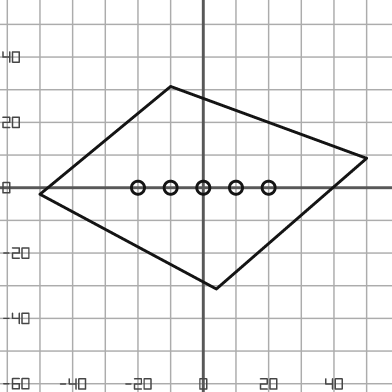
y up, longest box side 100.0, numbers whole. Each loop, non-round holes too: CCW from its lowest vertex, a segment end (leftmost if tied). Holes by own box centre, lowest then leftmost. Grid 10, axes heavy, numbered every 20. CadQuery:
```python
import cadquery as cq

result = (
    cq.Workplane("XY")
    .moveTo(4.0, -31.0)
    .lineTo(50.0, 9.0)
    .lineTo(-10.0, 31.0)
    .lineTo(-50.0, -2.0)
    .close()
    .moveTo(-20.0, 0.0)
    .circle(2.0)
    .moveTo(-10.0, 0.0)
    .circle(2.0)
    .moveTo(0.0, 0.0)
    .circle(2.0)
    .moveTo(10.0, 0.0)
    .circle(2.0)
    .moveTo(20.0, 0.0)
    .circle(2.0)
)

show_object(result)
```